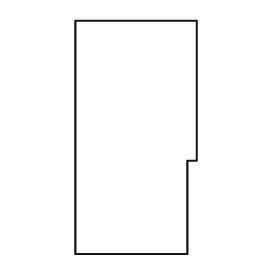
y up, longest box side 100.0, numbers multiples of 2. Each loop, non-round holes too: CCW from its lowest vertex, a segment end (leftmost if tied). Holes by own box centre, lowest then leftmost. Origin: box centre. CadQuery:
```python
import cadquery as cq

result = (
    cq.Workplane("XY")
    .moveTo(-26.0, -50.0)
    .lineTo(22.0, -50.0)
    .lineTo(22.0, -10.0)
    .lineTo(26.0, -10.0)
    .lineTo(26.0, 50.0)
    .lineTo(-26.0, 50.0)
    .close()
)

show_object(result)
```